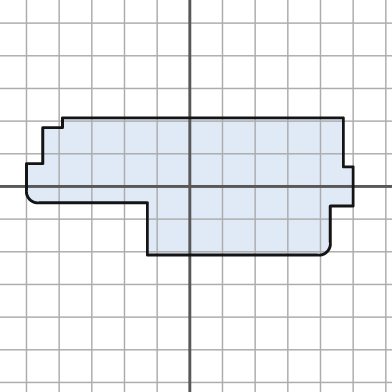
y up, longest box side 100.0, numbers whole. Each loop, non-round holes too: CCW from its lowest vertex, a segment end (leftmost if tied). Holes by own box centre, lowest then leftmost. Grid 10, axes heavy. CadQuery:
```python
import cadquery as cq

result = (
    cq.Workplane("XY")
    .moveTo(-13.0, -21.0)
    .lineTo(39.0, -21.0)
    .threePointArc((42.0, -20.0), (43.0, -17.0))
    .lineTo(43.0, -6.0)
    .lineTo(50.0, -6.0)
    .lineTo(50.0, 6.0)
    .lineTo(47.0, 6.0)
    .lineTo(47.0, 21.0)
    .lineTo(-39.0, 21.0)
    .lineTo(-39.0, 18.0)
    .lineTo(-45.0, 18.0)
    .lineTo(-45.0, 7.0)
    .lineTo(-50.0, 7.0)
    .lineTo(-50.0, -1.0)
    .threePointArc((-49.0, -4.0), (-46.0, -5.0))
    .lineTo(-13.0, -5.0)
    .close()
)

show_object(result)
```